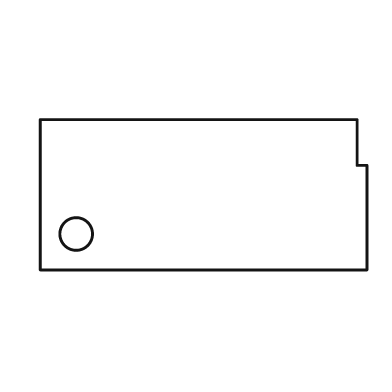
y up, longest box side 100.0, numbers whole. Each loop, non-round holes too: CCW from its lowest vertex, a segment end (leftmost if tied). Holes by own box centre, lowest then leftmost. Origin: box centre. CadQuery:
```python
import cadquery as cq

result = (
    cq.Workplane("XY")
    .moveTo(-50.0, -23.0)
    .lineTo(50.0, -23.0)
    .lineTo(50.0, 9.0)
    .lineTo(47.0, 9.0)
    .lineTo(47.0, 23.0)
    .lineTo(-50.0, 23.0)
    .close()
    .moveTo(-39.0, -12.0)
    .circle(5.0)
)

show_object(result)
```